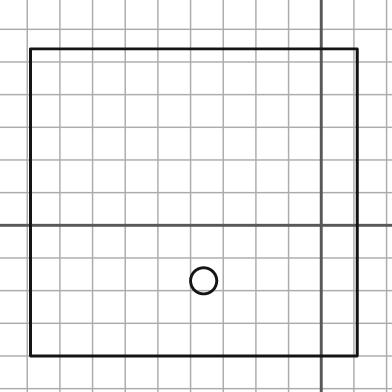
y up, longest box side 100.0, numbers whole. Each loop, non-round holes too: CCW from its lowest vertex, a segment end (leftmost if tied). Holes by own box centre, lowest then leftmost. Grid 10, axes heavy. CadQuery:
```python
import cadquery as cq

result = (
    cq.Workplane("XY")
    .moveTo(-89.0, -40.0)
    .lineTo(11.0, -40.0)
    .lineTo(11.0, 54.0)
    .lineTo(-89.0, 54.0)
    .close()
    .moveTo(-36.0, -17.0)
    .circle(4.0)
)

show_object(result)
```